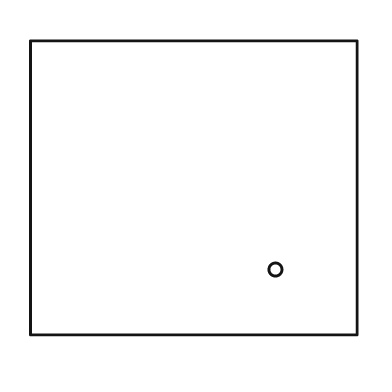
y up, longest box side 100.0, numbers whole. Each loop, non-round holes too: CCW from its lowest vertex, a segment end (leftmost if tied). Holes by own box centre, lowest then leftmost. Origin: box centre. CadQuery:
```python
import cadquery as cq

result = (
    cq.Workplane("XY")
    .moveTo(-50.0, -45.0)
    .lineTo(50.0, -45.0)
    .lineTo(50.0, 45.0)
    .lineTo(-50.0, 45.0)
    .close()
    .moveTo(25.0, -25.0)
    .circle(2.0)
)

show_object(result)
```